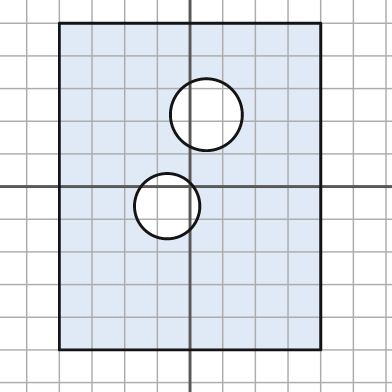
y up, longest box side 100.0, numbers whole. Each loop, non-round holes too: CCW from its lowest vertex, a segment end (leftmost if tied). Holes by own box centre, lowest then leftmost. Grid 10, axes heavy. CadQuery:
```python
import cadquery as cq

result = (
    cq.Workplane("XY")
    .moveTo(-40.0, -50.0)
    .lineTo(40.0, -50.0)
    .lineTo(40.0, 50.0)
    .lineTo(-40.0, 50.0)
    .close()
    .moveTo(-7.0, -6.0)
    .circle(10.0)
    .moveTo(5.0, 22.0)
    .circle(11.0)
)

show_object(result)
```